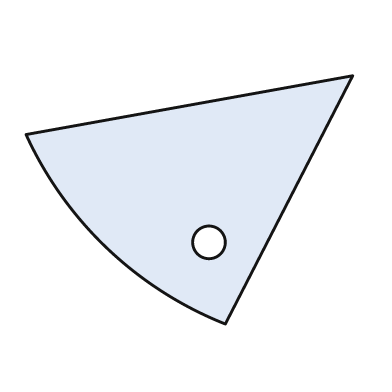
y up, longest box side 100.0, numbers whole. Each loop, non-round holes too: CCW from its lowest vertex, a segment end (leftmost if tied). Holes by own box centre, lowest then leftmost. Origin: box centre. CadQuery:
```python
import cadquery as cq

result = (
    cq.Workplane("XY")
    .moveTo(11.0, -38.0)
    .lineTo(50.0, 38.0)
    .lineTo(-50.0, 20.0)
    .threePointArc((-25.0, -15.0), (11.0, -38.0))
    .close()
    .moveTo(6.0, -13.0)
    .circle(5.0)
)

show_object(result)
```